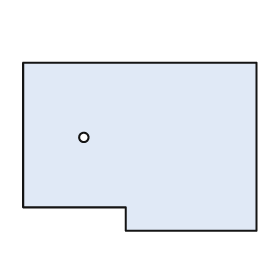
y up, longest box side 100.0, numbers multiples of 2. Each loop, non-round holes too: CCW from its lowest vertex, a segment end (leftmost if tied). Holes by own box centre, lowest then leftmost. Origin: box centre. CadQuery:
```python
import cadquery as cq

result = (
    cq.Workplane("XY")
    .moveTo(-6.0, -36.0)
    .lineTo(50.0, -36.0)
    .lineTo(50.0, 36.0)
    .lineTo(-50.0, 36.0)
    .lineTo(-50.0, -26.0)
    .lineTo(-6.0, -26.0)
    .close()
    .moveTo(-24.0, 4.0)
    .circle(2.0)
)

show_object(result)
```